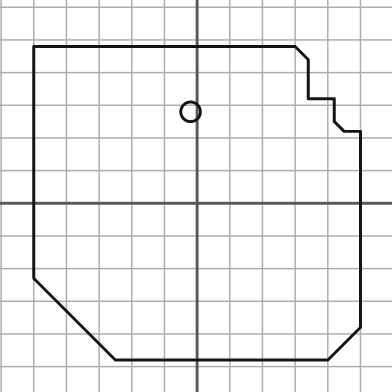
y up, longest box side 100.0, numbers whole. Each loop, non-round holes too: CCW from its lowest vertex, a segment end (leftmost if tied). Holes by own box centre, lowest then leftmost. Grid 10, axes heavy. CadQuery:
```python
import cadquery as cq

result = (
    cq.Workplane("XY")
    .moveTo(-25.0, -48.0)
    .lineTo(40.0, -48.0)
    .lineTo(50.0, -38.0)
    .lineTo(50.0, 22.0)
    .lineTo(45.0, 22.0)
    .lineTo(42.0, 25.0)
    .lineTo(42.0, 32.0)
    .lineTo(34.0, 32.0)
    .lineTo(34.0, 44.0)
    .lineTo(30.0, 48.0)
    .lineTo(-50.0, 48.0)
    .lineTo(-50.0, -23.0)
    .close()
    .moveTo(-2.0, 28.0)
    .circle(3.0)
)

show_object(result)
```